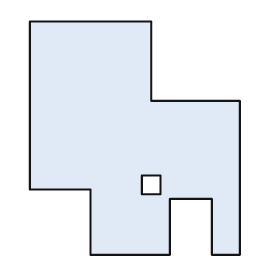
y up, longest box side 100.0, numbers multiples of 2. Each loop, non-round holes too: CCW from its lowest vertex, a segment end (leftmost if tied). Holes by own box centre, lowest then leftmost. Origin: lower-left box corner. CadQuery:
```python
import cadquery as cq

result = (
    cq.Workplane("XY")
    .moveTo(26.0, 0.0)
    .lineTo(60.0, 0.0)
    .lineTo(60.0, 24.0)
    .lineTo(78.0, 24.0)
    .lineTo(78.0, 0.0)
    .lineTo(90.0, 0.0)
    .lineTo(90.0, 66.0)
    .lineTo(52.0, 66.0)
    .lineTo(52.0, 100.0)
    .lineTo(0.0, 100.0)
    .lineTo(0.0, 28.0)
    .lineTo(26.0, 28.0)
    .close()
    .moveTo(48.0, 26.0)
    .lineTo(56.0, 26.0)
    .lineTo(56.0, 34.0)
    .lineTo(48.0, 34.0)
    .close()
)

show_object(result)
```